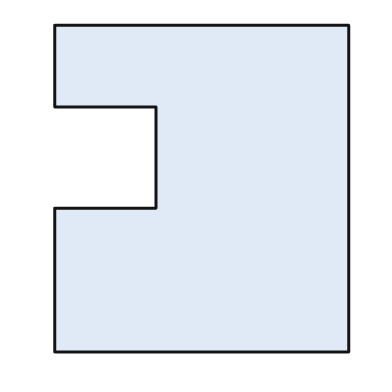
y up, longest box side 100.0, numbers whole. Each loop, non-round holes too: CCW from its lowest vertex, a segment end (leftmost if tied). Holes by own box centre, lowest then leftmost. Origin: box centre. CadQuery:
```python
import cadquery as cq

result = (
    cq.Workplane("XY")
    .moveTo(-45.0, -50.0)
    .lineTo(45.0, -50.0)
    .lineTo(45.0, 50.0)
    .lineTo(-45.0, 50.0)
    .lineTo(-45.0, 25.0)
    .lineTo(-14.0, 25.0)
    .lineTo(-14.0, -6.0)
    .lineTo(-45.0, -6.0)
    .close()
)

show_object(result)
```